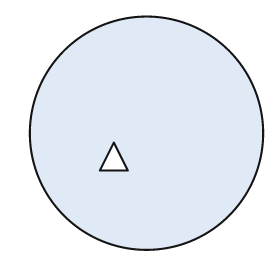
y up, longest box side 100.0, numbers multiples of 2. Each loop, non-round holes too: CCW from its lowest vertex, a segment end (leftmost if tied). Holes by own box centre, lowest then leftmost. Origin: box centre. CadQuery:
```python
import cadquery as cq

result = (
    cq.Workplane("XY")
    .moveTo(0.0, 0.0)
    .circle(50.0)
    .moveTo(-20.0, -16.0)
    .lineTo(-8.0, -16.0)
    .lineTo(-14.0, -4.0)
    .close()
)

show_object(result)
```